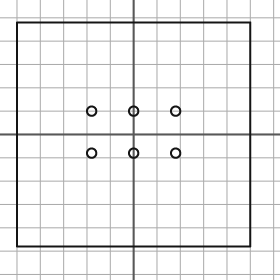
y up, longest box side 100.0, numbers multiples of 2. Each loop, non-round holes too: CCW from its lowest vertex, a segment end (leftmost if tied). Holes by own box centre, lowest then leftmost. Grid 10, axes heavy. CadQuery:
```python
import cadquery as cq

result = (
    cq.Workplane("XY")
    .moveTo(-50.0, -48.0)
    .lineTo(50.0, -48.0)
    .lineTo(50.0, 48.0)
    .lineTo(-50.0, 48.0)
    .close()
    .moveTo(-18.0, -8.0)
    .circle(2.0)
    .moveTo(0.0, -8.0)
    .circle(2.0)
    .moveTo(18.0, -8.0)
    .circle(2.0)
    .moveTo(-18.0, 10.0)
    .circle(2.0)
    .moveTo(0.0, 10.0)
    .circle(2.0)
    .moveTo(18.0, 10.0)
    .circle(2.0)
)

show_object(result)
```